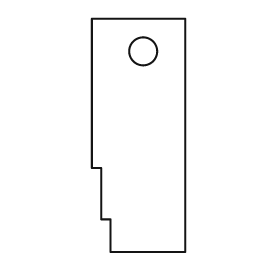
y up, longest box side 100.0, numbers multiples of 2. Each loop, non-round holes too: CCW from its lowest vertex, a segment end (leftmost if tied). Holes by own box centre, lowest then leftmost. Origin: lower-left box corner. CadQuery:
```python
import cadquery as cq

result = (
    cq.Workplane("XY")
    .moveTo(8.0, 0.0)
    .lineTo(40.0, 0.0)
    .lineTo(40.0, 100.0)
    .lineTo(0.0, 100.0)
    .lineTo(0.0, 36.0)
    .lineTo(4.0, 36.0)
    .lineTo(4.0, 14.0)
    .lineTo(8.0, 14.0)
    .close()
    .moveTo(22.0, 86.0)
    .circle(6.0)
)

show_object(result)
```